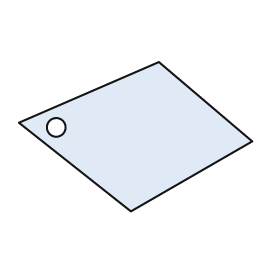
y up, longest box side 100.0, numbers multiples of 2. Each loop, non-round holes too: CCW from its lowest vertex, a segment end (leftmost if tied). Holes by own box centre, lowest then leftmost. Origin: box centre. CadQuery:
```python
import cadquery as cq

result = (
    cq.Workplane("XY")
    .moveTo(-2.0, -32.0)
    .lineTo(50.0, -2.0)
    .lineTo(10.0, 32.0)
    .lineTo(-50.0, 6.0)
    .close()
    .moveTo(-34.0, 4.0)
    .circle(4.0)
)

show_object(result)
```